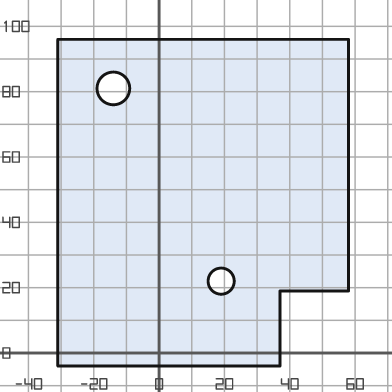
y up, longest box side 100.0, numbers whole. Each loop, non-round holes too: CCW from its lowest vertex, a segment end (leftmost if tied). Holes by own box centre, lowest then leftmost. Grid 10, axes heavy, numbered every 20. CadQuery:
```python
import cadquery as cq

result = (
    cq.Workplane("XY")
    .moveTo(-31.0, -4.0)
    .lineTo(37.0, -4.0)
    .lineTo(37.0, 19.0)
    .lineTo(58.0, 19.0)
    .lineTo(58.0, 96.0)
    .lineTo(-31.0, 96.0)
    .close()
    .moveTo(19.0, 22.0)
    .circle(4.0)
    .moveTo(-14.0, 81.0)
    .circle(5.0)
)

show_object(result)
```